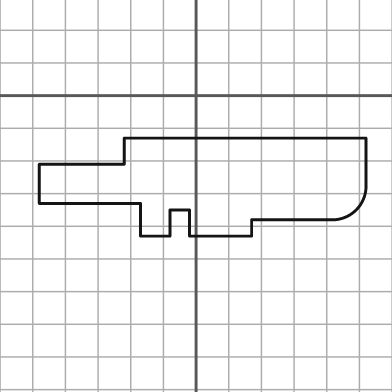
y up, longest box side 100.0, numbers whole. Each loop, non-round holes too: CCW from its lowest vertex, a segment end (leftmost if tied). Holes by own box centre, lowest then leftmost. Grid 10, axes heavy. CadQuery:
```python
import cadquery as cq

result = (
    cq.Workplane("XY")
    .moveTo(-17.0, -43.0)
    .lineTo(-8.0, -43.0)
    .lineTo(-8.0, -35.0)
    .lineTo(-2.0, -35.0)
    .lineTo(-2.0, -43.0)
    .lineTo(17.0, -43.0)
    .lineTo(17.0, -38.0)
    .lineTo(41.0, -38.0)
    .threePointArc((49.0, -35.0), (52.0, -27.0))
    .lineTo(52.0, -13.0)
    .lineTo(-22.0, -13.0)
    .lineTo(-22.0, -21.0)
    .lineTo(-48.0, -21.0)
    .lineTo(-48.0, -33.0)
    .lineTo(-17.0, -33.0)
    .close()
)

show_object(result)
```